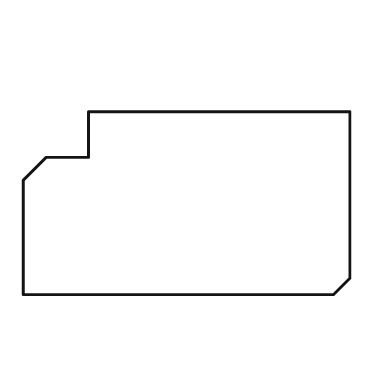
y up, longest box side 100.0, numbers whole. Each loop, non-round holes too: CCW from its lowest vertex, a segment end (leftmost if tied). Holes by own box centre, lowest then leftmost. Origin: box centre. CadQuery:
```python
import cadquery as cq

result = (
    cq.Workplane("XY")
    .moveTo(-50.0, -28.0)
    .lineTo(45.0, -28.0)
    .lineTo(50.0, -23.0)
    .lineTo(50.0, 28.0)
    .lineTo(-30.0, 28.0)
    .lineTo(-30.0, 14.0)
    .lineTo(-43.0, 14.0)
    .lineTo(-50.0, 7.0)
    .close()
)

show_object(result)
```